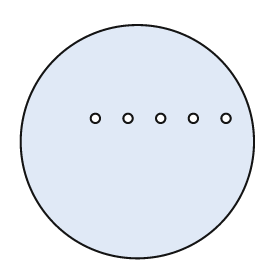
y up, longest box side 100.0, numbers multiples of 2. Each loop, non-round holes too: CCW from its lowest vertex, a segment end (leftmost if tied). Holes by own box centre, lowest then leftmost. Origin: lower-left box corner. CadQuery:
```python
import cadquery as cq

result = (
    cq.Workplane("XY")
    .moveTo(50.0, 50.0)
    .circle(50.0)
    .moveTo(32.0, 60.0)
    .circle(2.0)
    .moveTo(46.0, 60.0)
    .circle(2.0)
    .moveTo(60.0, 60.0)
    .circle(2.0)
    .moveTo(74.0, 60.0)
    .circle(2.0)
    .moveTo(88.0, 60.0)
    .circle(2.0)
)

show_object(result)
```